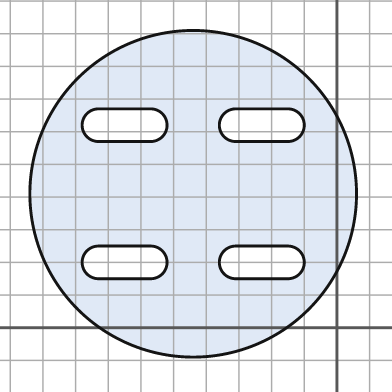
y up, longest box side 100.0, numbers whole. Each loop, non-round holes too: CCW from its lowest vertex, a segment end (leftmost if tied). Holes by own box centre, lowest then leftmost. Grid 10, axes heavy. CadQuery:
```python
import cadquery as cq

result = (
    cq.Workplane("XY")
    .moveTo(-44.0, 41.0)
    .circle(50.0)
    .moveTo(-73.0, 15.0)
    .lineTo(-57.0, 15.0)
    .threePointArc((-52.0, 20.0), (-57.0, 25.0))
    .lineTo(-73.0, 25.0)
    .threePointArc((-78.0, 20.0), (-73.0, 15.0))
    .close()
    .moveTo(-31.0, 15.0)
    .lineTo(-15.0, 15.0)
    .threePointArc((-10.0, 20.0), (-15.0, 25.0))
    .lineTo(-31.0, 25.0)
    .threePointArc((-36.0, 20.0), (-31.0, 15.0))
    .close()
    .moveTo(-73.0, 57.0)
    .lineTo(-57.0, 57.0)
    .threePointArc((-52.0, 62.0), (-57.0, 67.0))
    .lineTo(-73.0, 67.0)
    .threePointArc((-78.0, 62.0), (-73.0, 57.0))
    .close()
    .moveTo(-31.0, 57.0)
    .lineTo(-15.0, 57.0)
    .threePointArc((-10.0, 62.0), (-15.0, 67.0))
    .lineTo(-31.0, 67.0)
    .threePointArc((-36.0, 62.0), (-31.0, 57.0))
    .close()
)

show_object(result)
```